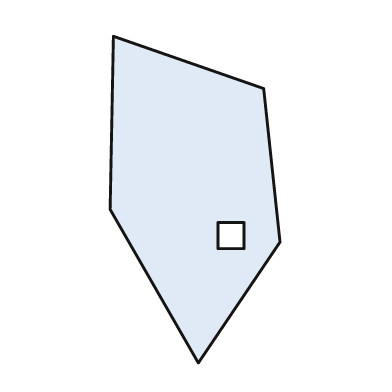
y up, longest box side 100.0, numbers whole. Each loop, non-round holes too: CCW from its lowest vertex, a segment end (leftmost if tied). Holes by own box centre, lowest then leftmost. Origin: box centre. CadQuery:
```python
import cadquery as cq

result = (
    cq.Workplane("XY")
    .moveTo(1.0, -50.0)
    .lineTo(26.0, -13.0)
    .lineTo(21.0, 34.0)
    .lineTo(-25.0, 50.0)
    .lineTo(-26.0, -3.0)
    .close()
    .moveTo(7.0, -15.0)
    .lineTo(15.0, -15.0)
    .lineTo(15.0, -7.0)
    .lineTo(7.0, -7.0)
    .close()
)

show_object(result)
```